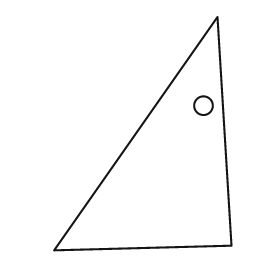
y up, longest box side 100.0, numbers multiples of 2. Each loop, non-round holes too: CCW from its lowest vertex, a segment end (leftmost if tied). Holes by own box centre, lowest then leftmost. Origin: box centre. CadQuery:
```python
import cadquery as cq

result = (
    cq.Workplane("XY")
    .moveTo(-38.0, -50.0)
    .lineTo(38.0, -48.0)
    .lineTo(32.0, 50.0)
    .close()
    .moveTo(26.0, 12.0)
    .circle(4.0)
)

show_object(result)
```